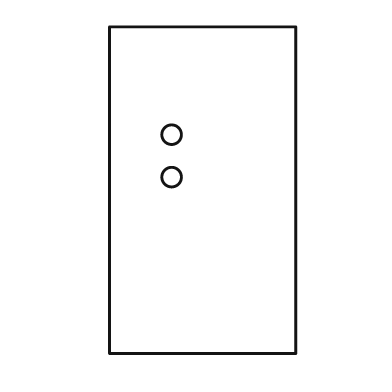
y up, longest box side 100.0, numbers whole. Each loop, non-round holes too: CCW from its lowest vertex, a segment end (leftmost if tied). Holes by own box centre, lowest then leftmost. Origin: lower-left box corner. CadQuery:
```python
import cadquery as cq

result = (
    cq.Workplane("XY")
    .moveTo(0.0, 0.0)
    .lineTo(57.0, 0.0)
    .lineTo(57.0, 100.0)
    .lineTo(0.0, 100.0)
    .close()
    .moveTo(19.0, 54.0)
    .circle(3.0)
    .moveTo(19.0, 67.0)
    .circle(3.0)
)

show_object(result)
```